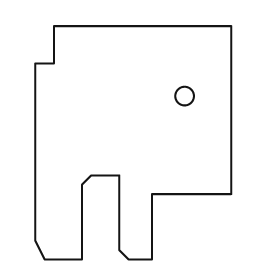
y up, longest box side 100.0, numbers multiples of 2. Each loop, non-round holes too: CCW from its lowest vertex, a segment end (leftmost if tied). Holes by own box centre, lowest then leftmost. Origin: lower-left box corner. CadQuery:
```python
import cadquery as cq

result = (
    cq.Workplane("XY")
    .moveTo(4.0, 0.0)
    .lineTo(20.0, 0.0)
    .lineTo(20.0, 32.0)
    .lineTo(24.0, 36.0)
    .lineTo(36.0, 36.0)
    .lineTo(36.0, 4.0)
    .lineTo(40.0, 0.0)
    .lineTo(50.0, 0.0)
    .lineTo(50.0, 28.0)
    .lineTo(84.0, 28.0)
    .lineTo(84.0, 100.0)
    .lineTo(8.0, 100.0)
    .lineTo(8.0, 84.0)
    .lineTo(0.0, 84.0)
    .lineTo(0.0, 8.0)
    .close()
    .moveTo(64.0, 70.0)
    .circle(4.0)
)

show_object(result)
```